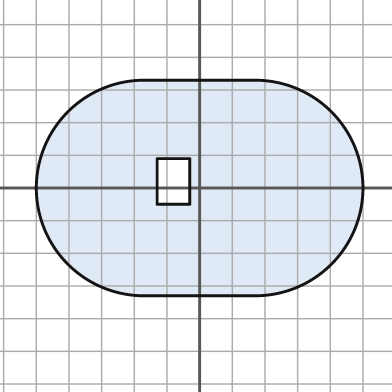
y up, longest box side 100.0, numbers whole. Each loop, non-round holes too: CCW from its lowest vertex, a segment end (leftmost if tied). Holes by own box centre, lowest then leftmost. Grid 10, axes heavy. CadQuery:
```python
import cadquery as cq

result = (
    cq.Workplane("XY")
    .moveTo(-17.0, -33.0)
    .lineTo(17.0, -33.0)
    .threePointArc((50.0, 0.0), (17.0, 33.0))
    .lineTo(-17.0, 33.0)
    .threePointArc((-50.0, 0.0), (-17.0, -33.0))
    .close()
    .moveTo(-13.0, -5.0)
    .lineTo(-3.0, -5.0)
    .lineTo(-3.0, 9.0)
    .lineTo(-13.0, 9.0)
    .close()
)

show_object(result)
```